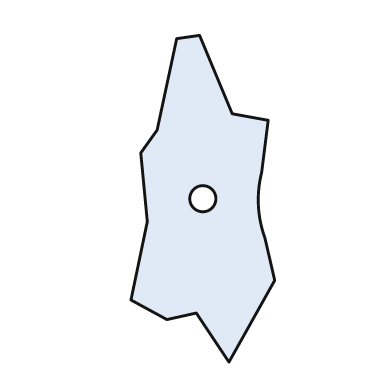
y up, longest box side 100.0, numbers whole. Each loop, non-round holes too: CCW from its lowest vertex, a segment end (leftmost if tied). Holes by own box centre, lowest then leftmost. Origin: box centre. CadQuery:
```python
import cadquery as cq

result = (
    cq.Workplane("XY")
    .moveTo(8.0, -50.0)
    .lineTo(22.0, -25.0)
    .lineTo(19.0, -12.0)
    .threePointArc((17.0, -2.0), (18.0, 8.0))
    .lineTo(20.0, 24.0)
    .lineTo(9.0, 26.0)
    .lineTo(-1.0, 50.0)
    .lineTo(-8.0, 49.0)
    .lineTo(-14.0, 21.0)
    .lineTo(-19.0, 14.0)
    .lineTo(-17.0, -7.0)
    .lineTo(-22.0, -31.0)
    .lineTo(-11.0, -37.0)
    .lineTo(-2.0, -35.0)
    .close()
    .moveTo(0.0, 0.0)
    .circle(4.0)
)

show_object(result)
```